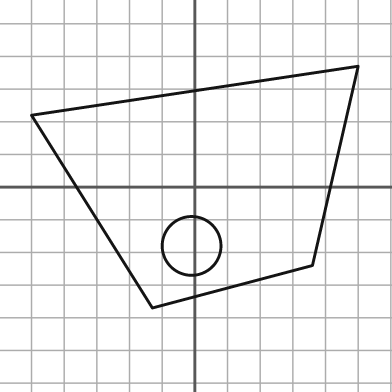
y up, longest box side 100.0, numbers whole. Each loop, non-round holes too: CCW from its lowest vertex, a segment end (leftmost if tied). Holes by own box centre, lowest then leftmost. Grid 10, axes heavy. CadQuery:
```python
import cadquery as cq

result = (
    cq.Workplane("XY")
    .moveTo(-13.0, -37.0)
    .lineTo(36.0, -24.0)
    .lineTo(50.0, 37.0)
    .lineTo(-50.0, 22.0)
    .close()
    .moveTo(-1.0, -18.0)
    .circle(9.0)
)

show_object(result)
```